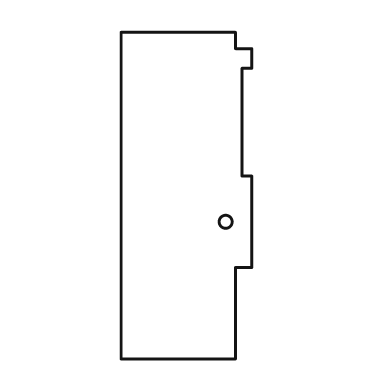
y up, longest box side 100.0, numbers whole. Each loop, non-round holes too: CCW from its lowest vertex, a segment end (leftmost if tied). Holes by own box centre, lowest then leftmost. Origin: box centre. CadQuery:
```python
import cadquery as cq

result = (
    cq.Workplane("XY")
    .moveTo(-20.0, -50.0)
    .lineTo(15.0, -50.0)
    .lineTo(15.0, -22.0)
    .lineTo(20.0, -22.0)
    .lineTo(20.0, 6.0)
    .lineTo(17.0, 6.0)
    .lineTo(17.0, 39.0)
    .lineTo(20.0, 39.0)
    .lineTo(20.0, 45.0)
    .lineTo(15.0, 45.0)
    .lineTo(15.0, 50.0)
    .lineTo(-20.0, 50.0)
    .close()
    .moveTo(12.0, -8.0)
    .circle(2.0)
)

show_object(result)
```